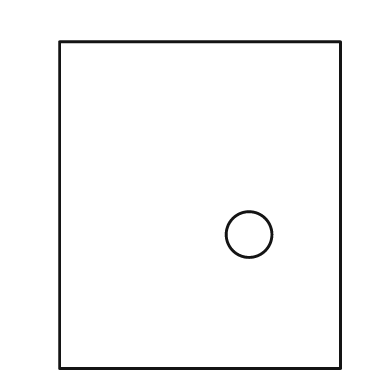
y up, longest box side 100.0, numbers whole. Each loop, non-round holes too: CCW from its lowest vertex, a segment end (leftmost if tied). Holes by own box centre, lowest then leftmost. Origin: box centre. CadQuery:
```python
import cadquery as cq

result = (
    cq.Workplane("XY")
    .moveTo(-43.0, -50.0)
    .lineTo(43.0, -50.0)
    .lineTo(43.0, 50.0)
    .lineTo(-43.0, 50.0)
    .close()
    .moveTo(15.0, -9.0)
    .circle(7.0)
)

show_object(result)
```